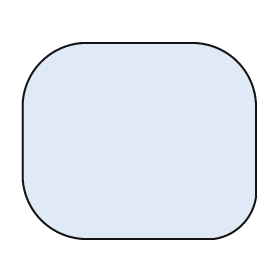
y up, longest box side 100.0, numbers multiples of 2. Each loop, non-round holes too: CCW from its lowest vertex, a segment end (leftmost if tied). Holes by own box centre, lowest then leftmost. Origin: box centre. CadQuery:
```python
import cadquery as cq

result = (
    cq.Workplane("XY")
    .moveTo(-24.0, -42.0)
    .lineTo(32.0, -42.0)
    .threePointArc((44.0, -36.0), (50.0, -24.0))
    .lineTo(50.0, 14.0)
    .threePointArc((42.0, 34.0), (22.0, 42.0))
    .lineTo(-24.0, 42.0)
    .threePointArc((-42.0, 34.0), (-50.0, 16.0))
    .lineTo(-50.0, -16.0)
    .threePointArc((-42.0, -34.0), (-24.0, -42.0))
    .close()
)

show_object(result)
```